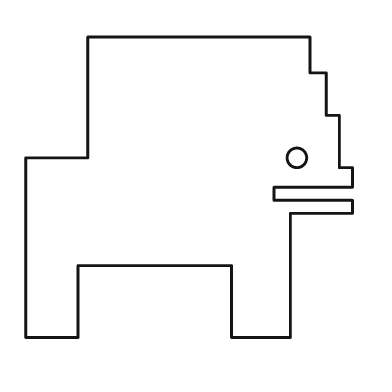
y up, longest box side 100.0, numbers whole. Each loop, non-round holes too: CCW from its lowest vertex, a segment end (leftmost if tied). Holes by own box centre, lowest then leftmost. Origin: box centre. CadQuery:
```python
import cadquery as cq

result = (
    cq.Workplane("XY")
    .moveTo(-50.0, -46.0)
    .lineTo(-34.0, -46.0)
    .lineTo(-34.0, -24.0)
    .lineTo(13.0, -24.0)
    .lineTo(13.0, -46.0)
    .lineTo(31.0, -46.0)
    .lineTo(31.0, -8.0)
    .lineTo(50.0, -8.0)
    .lineTo(50.0, -4.0)
    .lineTo(26.0, -4.0)
    .lineTo(26.0, 0.0)
    .lineTo(50.0, 0.0)
    .lineTo(50.0, 6.0)
    .lineTo(46.0, 6.0)
    .lineTo(46.0, 22.0)
    .lineTo(42.0, 22.0)
    .lineTo(42.0, 35.0)
    .lineTo(37.0, 35.0)
    .lineTo(37.0, 46.0)
    .lineTo(-31.0, 46.0)
    .lineTo(-31.0, 9.0)
    .lineTo(-50.0, 9.0)
    .close()
    .moveTo(33.0, 9.0)
    .circle(3.0)
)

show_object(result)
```